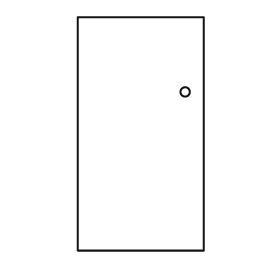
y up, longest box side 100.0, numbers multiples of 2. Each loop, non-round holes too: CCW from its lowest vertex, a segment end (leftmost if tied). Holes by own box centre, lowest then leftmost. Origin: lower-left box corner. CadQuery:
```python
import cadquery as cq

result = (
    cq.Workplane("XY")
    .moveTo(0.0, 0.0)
    .lineTo(54.0, 0.0)
    .lineTo(54.0, 100.0)
    .lineTo(0.0, 100.0)
    .close()
    .moveTo(46.0, 68.0)
    .circle(2.0)
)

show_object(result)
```